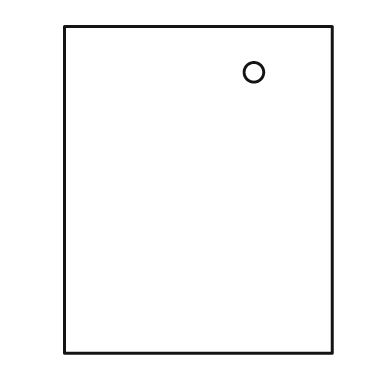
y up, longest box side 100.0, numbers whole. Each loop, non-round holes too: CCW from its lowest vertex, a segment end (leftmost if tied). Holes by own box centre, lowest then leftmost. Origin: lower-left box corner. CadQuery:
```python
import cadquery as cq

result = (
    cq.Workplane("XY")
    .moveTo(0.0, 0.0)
    .lineTo(82.0, 0.0)
    .lineTo(82.0, 100.0)
    .lineTo(0.0, 100.0)
    .close()
    .moveTo(58.0, 86.0)
    .circle(3.0)
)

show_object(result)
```